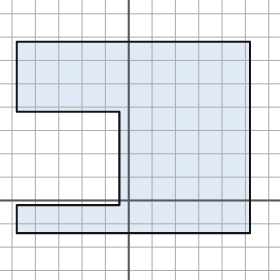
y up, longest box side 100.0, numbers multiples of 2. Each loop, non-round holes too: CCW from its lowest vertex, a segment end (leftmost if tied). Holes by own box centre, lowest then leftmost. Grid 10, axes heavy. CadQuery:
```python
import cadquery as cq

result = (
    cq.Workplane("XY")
    .moveTo(-48.0, -14.0)
    .lineTo(52.0, -14.0)
    .lineTo(52.0, 68.0)
    .lineTo(-48.0, 68.0)
    .lineTo(-48.0, 38.0)
    .lineTo(-4.0, 38.0)
    .lineTo(-4.0, -2.0)
    .lineTo(-48.0, -2.0)
    .close()
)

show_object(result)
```